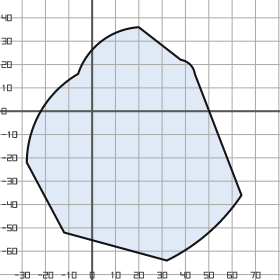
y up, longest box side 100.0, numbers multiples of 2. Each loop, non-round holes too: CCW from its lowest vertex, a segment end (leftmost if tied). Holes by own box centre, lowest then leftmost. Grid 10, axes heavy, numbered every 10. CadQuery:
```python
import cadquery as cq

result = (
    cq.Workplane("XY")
    .moveTo(32.0, -64.0)
    .threePointArc((50.0, -52.0), (64.0, -36.0))
    .lineTo(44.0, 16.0)
    .threePointArc((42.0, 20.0), (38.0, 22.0))
    .lineTo(20.0, 36.0)
    .threePointArc((4.0, 30.0), (-6.0, 16.0))
    .threePointArc((-22.0, 0.0), (-28.0, -22.0))
    .lineTo(-12.0, -52.0)
    .close()
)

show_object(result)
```